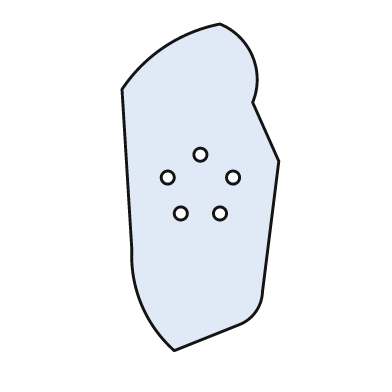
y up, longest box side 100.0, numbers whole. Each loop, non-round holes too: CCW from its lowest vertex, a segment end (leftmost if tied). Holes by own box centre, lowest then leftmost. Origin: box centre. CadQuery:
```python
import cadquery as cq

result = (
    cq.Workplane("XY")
    .moveTo(-8.0, -50.0)
    .lineTo(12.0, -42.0)
    .threePointArc((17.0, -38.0), (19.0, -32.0))
    .lineTo(24.0, 8.0)
    .lineTo(16.0, 26.0)
    .threePointArc((16.0, 40.0), (6.0, 50.0))
    .threePointArc((-11.0, 43.0), (-24.0, 30.0))
    .lineTo(-21.0, -19.0)
    .threePointArc((-18.0, -36.0), (-8.0, -50.0))
    .close()
    .moveTo(-6.0, -8.0)
    .circle(2.0)
    .moveTo(6.0, -8.0)
    .circle(2.0)
    .moveTo(-10.0, 3.0)
    .circle(2.0)
    .moveTo(10.0, 3.0)
    .circle(2.0)
    .moveTo(0.0, 10.0)
    .circle(2.0)
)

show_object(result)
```